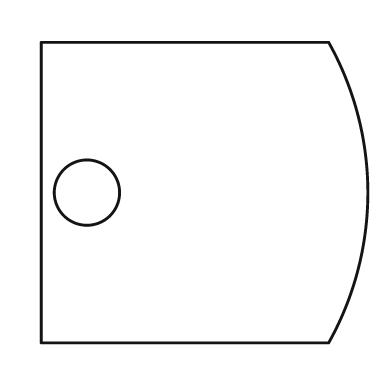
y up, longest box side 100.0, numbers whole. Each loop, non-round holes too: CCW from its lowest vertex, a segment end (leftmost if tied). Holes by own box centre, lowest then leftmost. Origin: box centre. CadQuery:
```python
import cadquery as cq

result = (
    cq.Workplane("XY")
    .moveTo(-50.0, -46.0)
    .lineTo(38.0, -46.0)
    .threePointArc((50.0, 0.0), (38.0, 46.0))
    .lineTo(-50.0, 46.0)
    .close()
    .moveTo(-36.0, 0.0)
    .circle(10.0)
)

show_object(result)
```